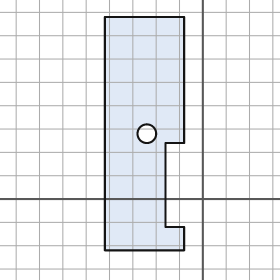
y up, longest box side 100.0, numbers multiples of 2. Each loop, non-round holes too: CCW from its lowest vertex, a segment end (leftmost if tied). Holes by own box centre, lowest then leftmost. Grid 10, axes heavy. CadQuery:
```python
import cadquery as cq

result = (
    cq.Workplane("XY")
    .moveTo(-42.0, -22.0)
    .lineTo(-8.0, -22.0)
    .lineTo(-8.0, -12.0)
    .lineTo(-16.0, -12.0)
    .lineTo(-16.0, 24.0)
    .lineTo(-8.0, 24.0)
    .lineTo(-8.0, 78.0)
    .lineTo(-42.0, 78.0)
    .close()
    .moveTo(-24.0, 28.0)
    .circle(4.0)
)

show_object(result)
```